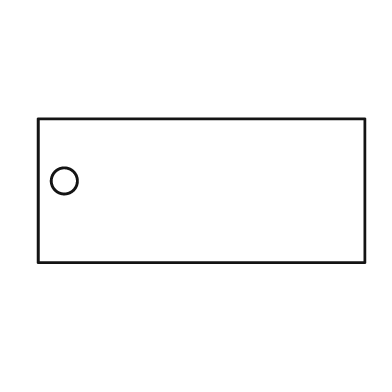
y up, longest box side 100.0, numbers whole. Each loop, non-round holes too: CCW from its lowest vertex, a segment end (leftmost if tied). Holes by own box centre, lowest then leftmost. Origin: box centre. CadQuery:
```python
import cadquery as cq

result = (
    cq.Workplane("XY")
    .moveTo(-50.0, -22.0)
    .lineTo(50.0, -22.0)
    .lineTo(50.0, 22.0)
    .lineTo(-50.0, 22.0)
    .close()
    .moveTo(-42.0, 3.0)
    .circle(4.0)
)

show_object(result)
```